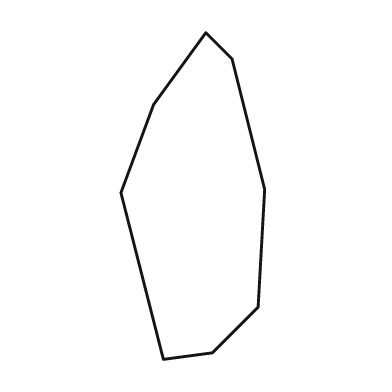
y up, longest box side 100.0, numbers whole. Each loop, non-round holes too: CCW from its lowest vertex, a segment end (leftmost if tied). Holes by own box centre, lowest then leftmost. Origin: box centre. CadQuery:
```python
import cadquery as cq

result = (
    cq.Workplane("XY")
    .moveTo(-9.0, -50.0)
    .lineTo(6.0, -48.0)
    .lineTo(20.0, -34.0)
    .lineTo(22.0, 2.0)
    .lineTo(12.0, 42.0)
    .lineTo(4.0, 50.0)
    .lineTo(-12.0, 28.0)
    .lineTo(-22.0, 1.0)
    .close()
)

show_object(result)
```